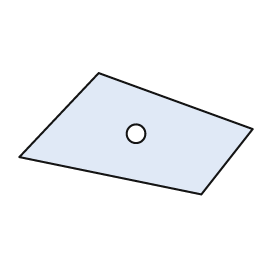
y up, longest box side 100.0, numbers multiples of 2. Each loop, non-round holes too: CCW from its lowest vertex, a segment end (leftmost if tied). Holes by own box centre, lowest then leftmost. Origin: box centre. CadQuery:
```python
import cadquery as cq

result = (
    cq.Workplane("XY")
    .moveTo(28.0, -26.0)
    .lineTo(50.0, 2.0)
    .lineTo(-16.0, 26.0)
    .lineTo(-50.0, -10.0)
    .close()
    .moveTo(0.0, 0.0)
    .circle(4.0)
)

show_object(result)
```